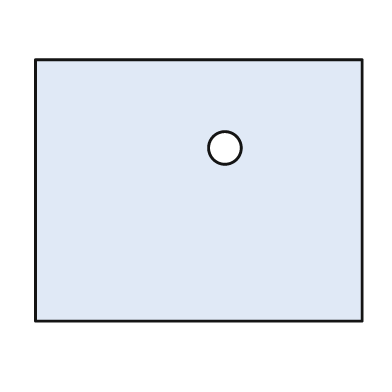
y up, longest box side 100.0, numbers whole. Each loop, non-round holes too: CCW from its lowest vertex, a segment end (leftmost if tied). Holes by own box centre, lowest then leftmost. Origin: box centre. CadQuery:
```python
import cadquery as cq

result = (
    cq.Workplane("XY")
    .moveTo(-50.0, -40.0)
    .lineTo(50.0, -40.0)
    .lineTo(50.0, 40.0)
    .lineTo(-50.0, 40.0)
    .close()
    .moveTo(8.0, 13.0)
    .circle(5.0)
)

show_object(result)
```